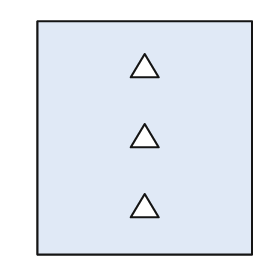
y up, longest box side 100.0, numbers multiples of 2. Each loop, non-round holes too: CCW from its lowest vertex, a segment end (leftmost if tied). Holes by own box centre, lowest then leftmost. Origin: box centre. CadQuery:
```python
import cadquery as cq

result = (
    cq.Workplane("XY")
    .moveTo(-46.0, -50.0)
    .lineTo(46.0, -50.0)
    .lineTo(46.0, 50.0)
    .lineTo(-46.0, 50.0)
    .close()
    .moveTo(-6.0, -34.0)
    .lineTo(6.0, -34.0)
    .lineTo(0.0, -24.0)
    .close()
    .moveTo(-6.0, -4.0)
    .lineTo(6.0, -4.0)
    .lineTo(0.0, 6.0)
    .close()
    .moveTo(-6.0, 26.0)
    .lineTo(6.0, 26.0)
    .lineTo(0.0, 36.0)
    .close()
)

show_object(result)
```